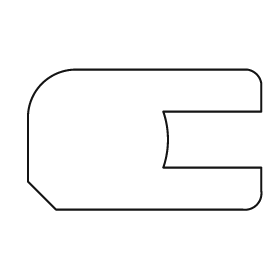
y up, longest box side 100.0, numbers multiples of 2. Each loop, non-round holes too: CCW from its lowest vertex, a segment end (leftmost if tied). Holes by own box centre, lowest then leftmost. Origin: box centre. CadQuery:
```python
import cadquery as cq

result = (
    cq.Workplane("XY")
    .moveTo(-38.0, -30.0)
    .lineTo(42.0, -30.0)
    .threePointArc((48.0, -28.0), (50.0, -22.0))
    .lineTo(50.0, -12.0)
    .lineTo(8.0, -12.0)
    .threePointArc((10.0, 0.0), (8.0, 12.0))
    .lineTo(50.0, 12.0)
    .lineTo(50.0, 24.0)
    .threePointArc((48.0, 28.0), (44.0, 30.0))
    .lineTo(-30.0, 30.0)
    .threePointArc((-44.0, 24.0), (-50.0, 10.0))
    .lineTo(-50.0, -18.0)
    .close()
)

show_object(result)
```